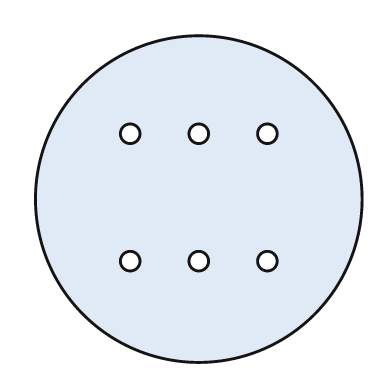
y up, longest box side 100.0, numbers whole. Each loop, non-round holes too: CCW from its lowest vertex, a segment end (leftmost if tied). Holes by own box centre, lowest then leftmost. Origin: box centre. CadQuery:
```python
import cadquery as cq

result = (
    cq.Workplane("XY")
    .moveTo(0.0, 0.0)
    .circle(50.0)
    .moveTo(-21.0, -19.0)
    .circle(3.0)
    .moveTo(0.0, -19.0)
    .circle(3.0)
    .moveTo(21.0, -19.0)
    .circle(3.0)
    .moveTo(-21.0, 20.0)
    .circle(3.0)
    .moveTo(0.0, 20.0)
    .circle(3.0)
    .moveTo(21.0, 20.0)
    .circle(3.0)
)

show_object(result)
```